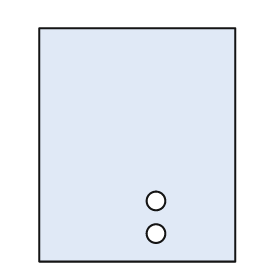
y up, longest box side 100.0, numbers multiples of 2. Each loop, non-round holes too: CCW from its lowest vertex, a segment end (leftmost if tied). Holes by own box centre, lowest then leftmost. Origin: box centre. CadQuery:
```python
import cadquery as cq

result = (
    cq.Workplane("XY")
    .moveTo(-42.0, -50.0)
    .lineTo(42.0, -50.0)
    .lineTo(42.0, 50.0)
    .lineTo(-42.0, 50.0)
    .close()
    .moveTo(8.0, -38.0)
    .circle(4.0)
    .moveTo(8.0, -24.0)
    .circle(4.0)
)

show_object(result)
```